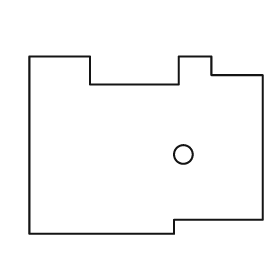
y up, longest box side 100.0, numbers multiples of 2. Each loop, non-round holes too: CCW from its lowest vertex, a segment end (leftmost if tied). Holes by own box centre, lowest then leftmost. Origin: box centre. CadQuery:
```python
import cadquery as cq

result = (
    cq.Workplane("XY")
    .moveTo(-50.0, -38.0)
    .lineTo(12.0, -38.0)
    .lineTo(12.0, -32.0)
    .lineTo(50.0, -32.0)
    .lineTo(50.0, 30.0)
    .lineTo(28.0, 30.0)
    .lineTo(28.0, 38.0)
    .lineTo(14.0, 38.0)
    .lineTo(14.0, 26.0)
    .lineTo(-24.0, 26.0)
    .lineTo(-24.0, 38.0)
    .lineTo(-50.0, 38.0)
    .close()
    .moveTo(16.0, -4.0)
    .circle(4.0)
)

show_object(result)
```